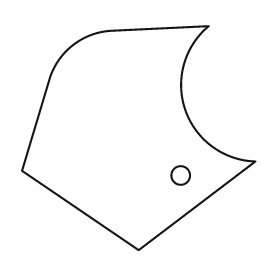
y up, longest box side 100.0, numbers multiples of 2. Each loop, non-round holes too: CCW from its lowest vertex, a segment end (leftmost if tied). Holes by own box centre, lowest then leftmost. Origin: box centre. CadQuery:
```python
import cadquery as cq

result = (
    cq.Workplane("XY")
    .moveTo(0.0, -48.0)
    .lineTo(50.0, -10.0)
    .threePointArc((20.0, 12.0), (30.0, 48.0))
    .lineTo(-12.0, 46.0)
    .threePointArc((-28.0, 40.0), (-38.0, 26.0))
    .lineTo(-50.0, -14.0)
    .close()
    .moveTo(18.0, -16.0)
    .circle(4.0)
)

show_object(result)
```